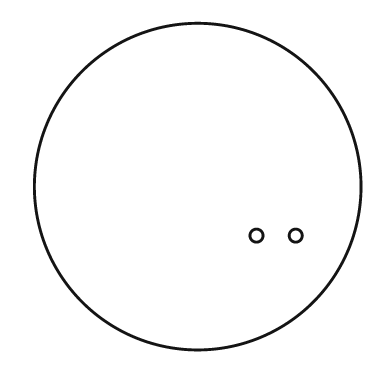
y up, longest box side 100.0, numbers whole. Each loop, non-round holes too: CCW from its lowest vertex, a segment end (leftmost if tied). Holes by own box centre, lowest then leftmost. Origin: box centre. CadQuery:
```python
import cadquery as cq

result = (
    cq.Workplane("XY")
    .moveTo(0.0, 0.0)
    .circle(50.0)
    .moveTo(18.0, -15.0)
    .circle(2.0)
    .moveTo(30.0, -15.0)
    .circle(2.0)
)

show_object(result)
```